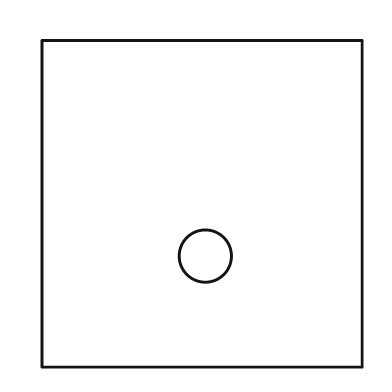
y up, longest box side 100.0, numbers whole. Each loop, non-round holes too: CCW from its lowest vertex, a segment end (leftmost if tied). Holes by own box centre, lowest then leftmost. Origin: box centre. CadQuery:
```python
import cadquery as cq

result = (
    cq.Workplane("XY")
    .moveTo(-49.0, -50.0)
    .lineTo(49.0, -50.0)
    .lineTo(49.0, 50.0)
    .lineTo(-49.0, 50.0)
    .close()
    .moveTo(1.0, -16.0)
    .circle(8.0)
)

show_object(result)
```